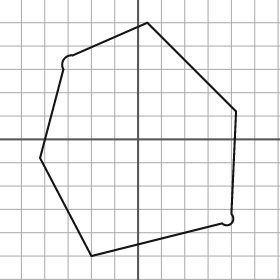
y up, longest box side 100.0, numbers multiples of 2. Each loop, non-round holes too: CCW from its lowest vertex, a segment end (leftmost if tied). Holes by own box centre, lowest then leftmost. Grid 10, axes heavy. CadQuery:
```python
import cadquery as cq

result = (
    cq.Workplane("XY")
    .moveTo(-20.0, -50.0)
    .lineTo(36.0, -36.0)
    .threePointArc((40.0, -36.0), (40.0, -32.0))
    .lineTo(42.0, 12.0)
    .lineTo(4.0, 50.0)
    .lineTo(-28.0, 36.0)
    .threePointArc((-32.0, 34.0), (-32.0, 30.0))
    .lineTo(-42.0, -8.0)
    .close()
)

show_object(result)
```